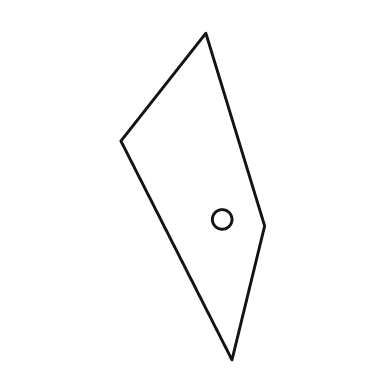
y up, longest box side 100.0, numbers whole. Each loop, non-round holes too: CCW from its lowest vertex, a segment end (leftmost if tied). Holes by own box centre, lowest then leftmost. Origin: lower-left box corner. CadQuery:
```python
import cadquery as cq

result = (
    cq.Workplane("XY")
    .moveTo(34.0, 0.0)
    .lineTo(44.0, 41.0)
    .lineTo(26.0, 100.0)
    .lineTo(0.0, 67.0)
    .close()
    .moveTo(31.0, 43.0)
    .circle(3.0)
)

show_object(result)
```